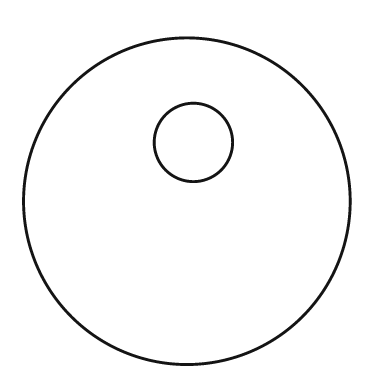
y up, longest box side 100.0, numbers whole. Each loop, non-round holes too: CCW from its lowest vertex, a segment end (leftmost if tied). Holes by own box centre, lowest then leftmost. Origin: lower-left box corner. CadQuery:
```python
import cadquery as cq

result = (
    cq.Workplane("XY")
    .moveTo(50.0, 50.0)
    .circle(50.0)
    .moveTo(52.0, 68.0)
    .circle(12.0)
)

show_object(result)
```